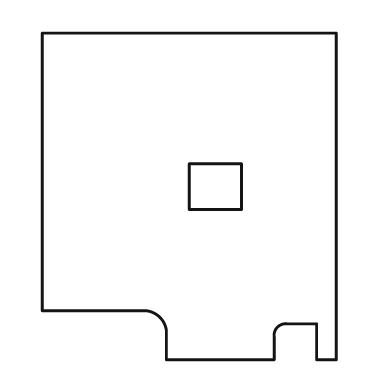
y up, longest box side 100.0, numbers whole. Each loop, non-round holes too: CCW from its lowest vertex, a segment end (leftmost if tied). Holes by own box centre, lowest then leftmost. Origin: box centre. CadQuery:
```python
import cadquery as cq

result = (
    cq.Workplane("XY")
    .moveTo(-7.0, -50.0)
    .lineTo(26.0, -50.0)
    .lineTo(26.0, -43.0)
    .threePointArc((27.0, -40.0), (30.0, -39.0))
    .lineTo(39.0, -39.0)
    .lineTo(39.0, -50.0)
    .lineTo(45.0, -50.0)
    .lineTo(45.0, 50.0)
    .lineTo(-45.0, 50.0)
    .lineTo(-45.0, -35.0)
    .lineTo(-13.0, -35.0)
    .threePointArc((-9.0, -37.0), (-7.0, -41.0))
    .close()
    .moveTo(0.0, -4.0)
    .lineTo(16.0, -4.0)
    .lineTo(16.0, 10.0)
    .lineTo(0.0, 10.0)
    .close()
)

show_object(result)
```